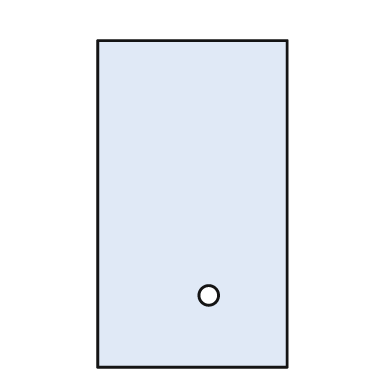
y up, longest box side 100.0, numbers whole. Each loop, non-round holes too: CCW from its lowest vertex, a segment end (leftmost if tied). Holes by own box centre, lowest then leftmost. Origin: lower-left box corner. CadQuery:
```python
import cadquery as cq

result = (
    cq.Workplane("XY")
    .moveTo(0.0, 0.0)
    .lineTo(58.0, 0.0)
    .lineTo(58.0, 100.0)
    .lineTo(0.0, 100.0)
    .close()
    .moveTo(34.0, 22.0)
    .circle(3.0)
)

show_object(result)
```